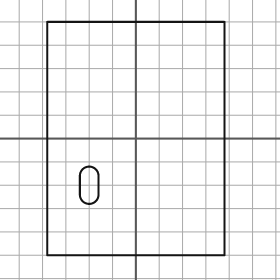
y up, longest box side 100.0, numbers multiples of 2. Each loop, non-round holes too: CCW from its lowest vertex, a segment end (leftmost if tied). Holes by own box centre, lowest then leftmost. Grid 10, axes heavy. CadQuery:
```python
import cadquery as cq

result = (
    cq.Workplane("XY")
    .moveTo(-38.0, -50.0)
    .lineTo(38.0, -50.0)
    .lineTo(38.0, 50.0)
    .lineTo(-38.0, 50.0)
    .close()
    .moveTo(-24.0, -24.0)
    .threePointArc((-20.0, -28.0), (-16.0, -24.0))
    .lineTo(-16.0, -16.0)
    .threePointArc((-20.0, -12.0), (-24.0, -16.0))
    .close()
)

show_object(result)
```